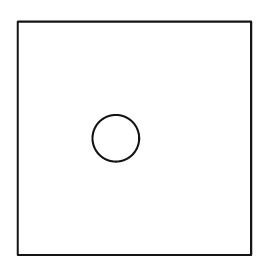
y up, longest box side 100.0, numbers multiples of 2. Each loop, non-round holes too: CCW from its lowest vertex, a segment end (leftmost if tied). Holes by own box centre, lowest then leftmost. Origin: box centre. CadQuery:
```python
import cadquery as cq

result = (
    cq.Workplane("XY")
    .moveTo(-50.0, -50.0)
    .lineTo(50.0, -50.0)
    .lineTo(50.0, 50.0)
    .lineTo(-50.0, 50.0)
    .close()
    .moveTo(-8.0, 0.0)
    .circle(10.0)
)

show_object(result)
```